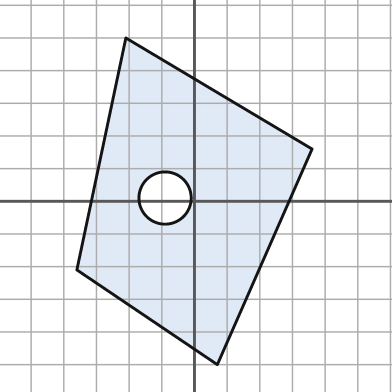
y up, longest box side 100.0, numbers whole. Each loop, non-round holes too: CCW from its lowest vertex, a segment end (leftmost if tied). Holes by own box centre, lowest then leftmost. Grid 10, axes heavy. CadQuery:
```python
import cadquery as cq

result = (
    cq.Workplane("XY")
    .moveTo(7.0, -50.0)
    .lineTo(36.0, 16.0)
    .lineTo(-21.0, 50.0)
    .lineTo(-36.0, -21.0)
    .close()
    .moveTo(-9.0, 1.0)
    .circle(8.0)
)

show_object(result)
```